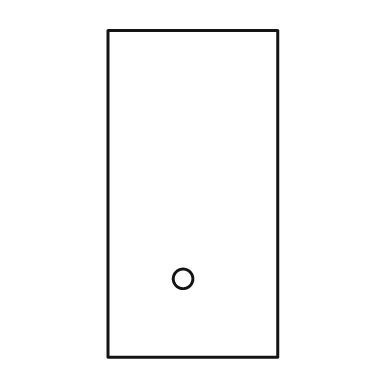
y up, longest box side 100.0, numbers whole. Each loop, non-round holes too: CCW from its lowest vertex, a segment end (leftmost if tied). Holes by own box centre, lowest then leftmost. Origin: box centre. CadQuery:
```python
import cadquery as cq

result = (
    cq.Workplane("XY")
    .moveTo(-26.0, -50.0)
    .lineTo(26.0, -50.0)
    .lineTo(26.0, 50.0)
    .lineTo(-26.0, 50.0)
    .close()
    .moveTo(-3.0, -26.0)
    .circle(3.0)
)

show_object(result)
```